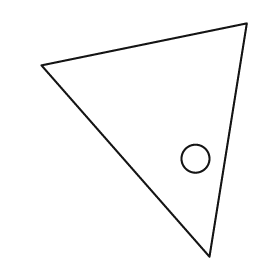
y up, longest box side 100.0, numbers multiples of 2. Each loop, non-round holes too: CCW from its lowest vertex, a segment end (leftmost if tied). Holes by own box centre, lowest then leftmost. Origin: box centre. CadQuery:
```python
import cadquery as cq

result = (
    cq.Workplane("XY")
    .moveTo(28.0, -50.0)
    .lineTo(44.0, 50.0)
    .lineTo(-44.0, 32.0)
    .close()
    .moveTo(22.0, -8.0)
    .circle(6.0)
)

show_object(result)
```